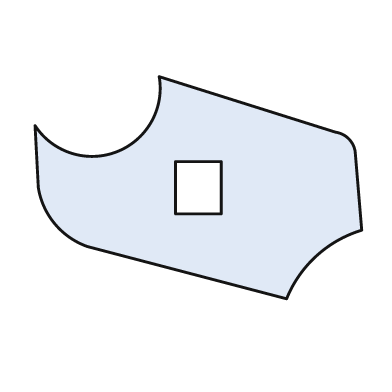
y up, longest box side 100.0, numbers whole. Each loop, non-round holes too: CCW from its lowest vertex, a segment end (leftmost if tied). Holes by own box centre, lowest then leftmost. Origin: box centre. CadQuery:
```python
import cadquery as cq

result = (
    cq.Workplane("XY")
    .moveTo(27.0, -34.0)
    .threePointArc((36.0, -21.0), (50.0, -13.0))
    .lineTo(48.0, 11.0)
    .threePointArc((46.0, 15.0), (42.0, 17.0))
    .lineTo(-12.0, 34.0)
    .threePointArc((-25.0, 11.0), (-50.0, 19.0))
    .lineTo(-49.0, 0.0)
    .threePointArc((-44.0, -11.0), (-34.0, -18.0))
    .close()
    .moveTo(-7.0, -8.0)
    .lineTo(7.0, -8.0)
    .lineTo(7.0, 8.0)
    .lineTo(-7.0, 8.0)
    .close()
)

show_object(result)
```